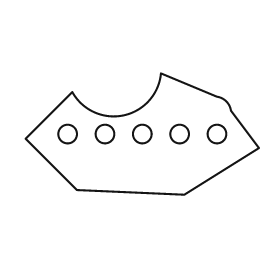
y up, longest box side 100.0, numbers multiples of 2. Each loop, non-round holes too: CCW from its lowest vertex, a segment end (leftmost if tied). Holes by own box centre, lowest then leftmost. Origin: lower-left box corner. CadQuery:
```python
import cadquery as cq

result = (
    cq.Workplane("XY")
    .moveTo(68.0, 0.0)
    .lineTo(100.0, 20.0)
    .lineTo(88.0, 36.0)
    .threePointArc((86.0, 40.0), (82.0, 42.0))
    .lineTo(58.0, 52.0)
    .threePointArc((42.0, 34.0), (20.0, 44.0))
    .lineTo(0.0, 24.0)
    .lineTo(22.0, 2.0)
    .close()
    .moveTo(18.0, 26.0)
    .circle(4.0)
    .moveTo(34.0, 26.0)
    .circle(4.0)
    .moveTo(50.0, 26.0)
    .circle(4.0)
    .moveTo(66.0, 26.0)
    .circle(4.0)
    .moveTo(82.0, 26.0)
    .circle(4.0)
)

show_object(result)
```